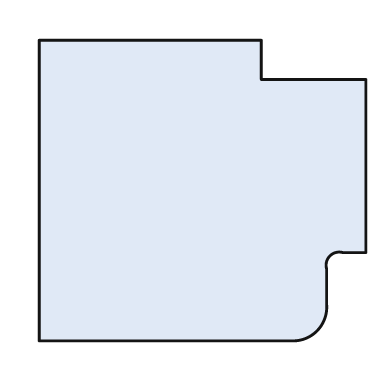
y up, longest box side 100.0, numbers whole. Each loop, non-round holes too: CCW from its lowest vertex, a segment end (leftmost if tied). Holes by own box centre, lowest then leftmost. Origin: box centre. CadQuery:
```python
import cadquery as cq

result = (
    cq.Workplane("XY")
    .moveTo(-50.0, -46.0)
    .lineTo(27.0, -46.0)
    .threePointArc((35.0, -43.0), (38.0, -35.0))
    .lineTo(38.0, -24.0)
    .threePointArc((39.0, -20.0), (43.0, -19.0))
    .lineTo(50.0, -19.0)
    .lineTo(50.0, 34.0)
    .lineTo(18.0, 34.0)
    .lineTo(18.0, 46.0)
    .lineTo(-50.0, 46.0)
    .close()
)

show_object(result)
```